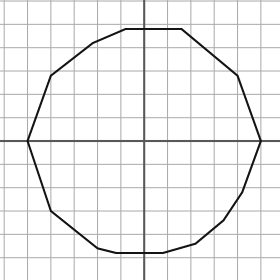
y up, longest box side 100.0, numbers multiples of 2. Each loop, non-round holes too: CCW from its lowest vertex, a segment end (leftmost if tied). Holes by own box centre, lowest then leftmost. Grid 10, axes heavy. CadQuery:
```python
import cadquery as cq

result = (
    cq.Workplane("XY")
    .moveTo(-12.0, -48.0)
    .lineTo(8.0, -48.0)
    .lineTo(22.0, -44.0)
    .lineTo(34.0, -34.0)
    .lineTo(42.0, -22.0)
    .lineTo(50.0, 0.0)
    .lineTo(40.0, 28.0)
    .lineTo(16.0, 48.0)
    .lineTo(-8.0, 48.0)
    .lineTo(-22.0, 42.0)
    .lineTo(-40.0, 28.0)
    .lineTo(-50.0, 0.0)
    .lineTo(-40.0, -30.0)
    .lineTo(-20.0, -46.0)
    .close()
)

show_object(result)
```